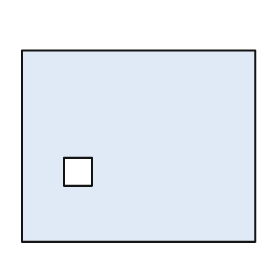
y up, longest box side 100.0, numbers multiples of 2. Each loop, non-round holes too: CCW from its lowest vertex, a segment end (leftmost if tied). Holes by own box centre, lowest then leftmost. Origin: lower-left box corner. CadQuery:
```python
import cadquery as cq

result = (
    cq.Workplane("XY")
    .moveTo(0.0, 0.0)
    .lineTo(100.0, 0.0)
    .lineTo(100.0, 82.0)
    .lineTo(0.0, 82.0)
    .close()
    .moveTo(18.0, 24.0)
    .lineTo(30.0, 24.0)
    .lineTo(30.0, 36.0)
    .lineTo(18.0, 36.0)
    .close()
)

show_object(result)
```